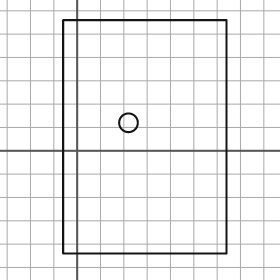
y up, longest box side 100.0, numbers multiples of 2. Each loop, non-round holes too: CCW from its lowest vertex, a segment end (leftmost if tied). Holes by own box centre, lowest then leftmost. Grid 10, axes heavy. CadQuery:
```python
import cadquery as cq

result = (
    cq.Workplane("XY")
    .moveTo(-6.0, -44.0)
    .lineTo(64.0, -44.0)
    .lineTo(64.0, 56.0)
    .lineTo(-6.0, 56.0)
    .close()
    .moveTo(22.0, 12.0)
    .circle(4.0)
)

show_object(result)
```